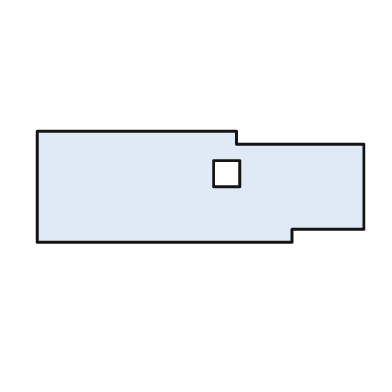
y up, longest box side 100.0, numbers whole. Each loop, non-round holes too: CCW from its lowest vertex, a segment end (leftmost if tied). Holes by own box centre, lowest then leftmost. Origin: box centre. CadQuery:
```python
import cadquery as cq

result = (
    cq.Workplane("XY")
    .moveTo(-50.0, -17.0)
    .lineTo(28.0, -17.0)
    .lineTo(28.0, -13.0)
    .lineTo(50.0, -13.0)
    .lineTo(50.0, 13.0)
    .lineTo(11.0, 13.0)
    .lineTo(11.0, 17.0)
    .lineTo(-50.0, 17.0)
    .close()
    .moveTo(4.0, 0.0)
    .lineTo(12.0, 0.0)
    .lineTo(12.0, 8.0)
    .lineTo(4.0, 8.0)
    .close()
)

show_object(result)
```